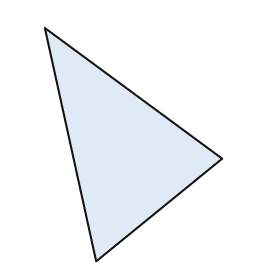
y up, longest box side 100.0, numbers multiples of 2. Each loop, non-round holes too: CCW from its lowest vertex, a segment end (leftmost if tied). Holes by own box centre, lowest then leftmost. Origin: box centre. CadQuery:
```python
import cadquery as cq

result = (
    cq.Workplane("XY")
    .moveTo(-16.0, -50.0)
    .lineTo(38.0, -6.0)
    .lineTo(-38.0, 50.0)
    .close()
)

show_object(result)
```